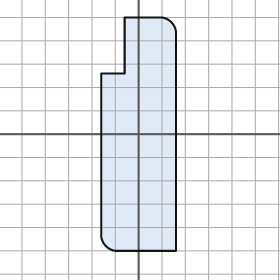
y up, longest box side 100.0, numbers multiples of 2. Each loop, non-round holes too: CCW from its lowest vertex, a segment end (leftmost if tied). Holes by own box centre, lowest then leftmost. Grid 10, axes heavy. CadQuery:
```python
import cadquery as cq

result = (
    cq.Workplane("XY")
    .moveTo(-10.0, -50.0)
    .lineTo(16.0, -50.0)
    .lineTo(16.0, 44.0)
    .threePointArc((14.0, 48.0), (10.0, 50.0))
    .lineTo(-6.0, 50.0)
    .lineTo(-6.0, 26.0)
    .lineTo(-16.0, 26.0)
    .lineTo(-16.0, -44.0)
    .threePointArc((-14.0, -48.0), (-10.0, -50.0))
    .close()
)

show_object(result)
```